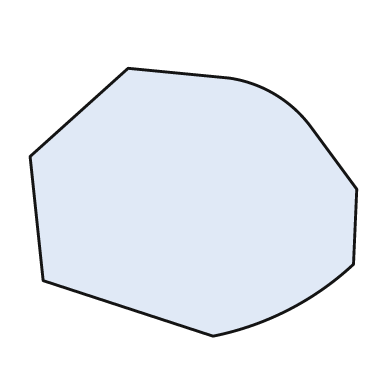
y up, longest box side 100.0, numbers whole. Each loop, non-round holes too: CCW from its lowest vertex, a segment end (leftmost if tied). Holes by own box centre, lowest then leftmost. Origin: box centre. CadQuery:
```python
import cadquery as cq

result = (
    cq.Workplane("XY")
    .moveTo(6.0, -41.0)
    .threePointArc((29.0, -33.0), (49.0, -19.0))
    .lineTo(50.0, 4.0)
    .lineTo(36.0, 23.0)
    .threePointArc((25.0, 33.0), (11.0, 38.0))
    .lineTo(-20.0, 41.0)
    .lineTo(-50.0, 14.0)
    .lineTo(-46.0, -24.0)
    .close()
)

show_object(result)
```